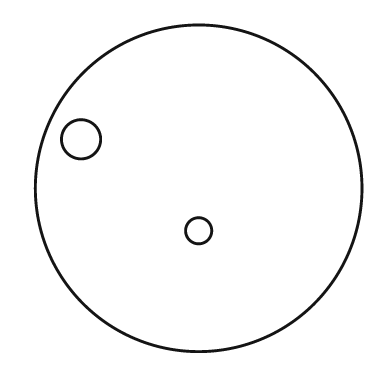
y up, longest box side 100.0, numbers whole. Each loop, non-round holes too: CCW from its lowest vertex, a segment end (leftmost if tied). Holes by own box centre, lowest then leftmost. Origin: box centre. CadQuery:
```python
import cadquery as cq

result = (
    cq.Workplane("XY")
    .moveTo(0.0, 0.0)
    .circle(50.0)
    .moveTo(0.0, -13.0)
    .circle(4.0)
    .moveTo(-36.0, 15.0)
    .circle(6.0)
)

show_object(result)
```